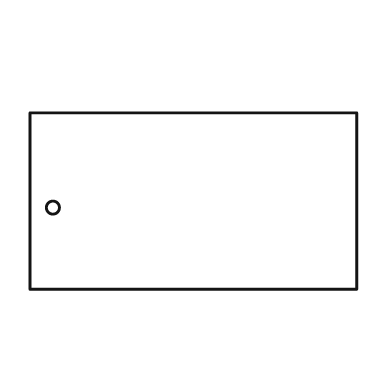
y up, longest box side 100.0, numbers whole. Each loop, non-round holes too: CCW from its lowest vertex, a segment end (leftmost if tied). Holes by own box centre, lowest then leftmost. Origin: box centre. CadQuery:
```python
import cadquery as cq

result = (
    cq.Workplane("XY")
    .moveTo(-50.0, -27.0)
    .lineTo(50.0, -27.0)
    .lineTo(50.0, 27.0)
    .lineTo(-50.0, 27.0)
    .close()
    .moveTo(-43.0, -2.0)
    .circle(2.0)
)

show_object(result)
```